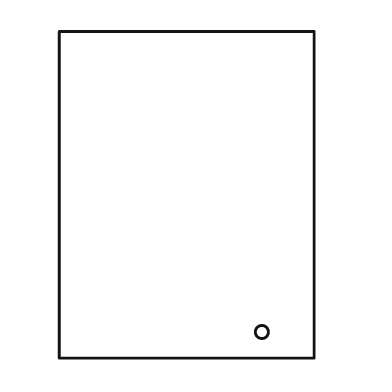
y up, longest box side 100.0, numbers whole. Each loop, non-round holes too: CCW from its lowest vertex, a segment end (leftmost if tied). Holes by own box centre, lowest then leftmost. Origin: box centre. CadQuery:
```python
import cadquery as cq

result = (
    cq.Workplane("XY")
    .moveTo(-39.0, -50.0)
    .lineTo(39.0, -50.0)
    .lineTo(39.0, 50.0)
    .lineTo(-39.0, 50.0)
    .close()
    .moveTo(23.0, -42.0)
    .circle(2.0)
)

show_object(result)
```